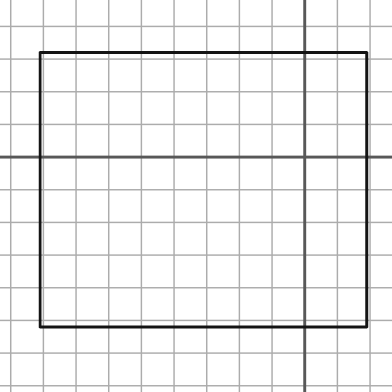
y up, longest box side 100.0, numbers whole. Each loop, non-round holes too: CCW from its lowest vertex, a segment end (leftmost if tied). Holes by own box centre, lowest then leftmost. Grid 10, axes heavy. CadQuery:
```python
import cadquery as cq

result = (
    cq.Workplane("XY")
    .moveTo(-81.0, -52.0)
    .lineTo(19.0, -52.0)
    .lineTo(19.0, 32.0)
    .lineTo(-81.0, 32.0)
    .close()
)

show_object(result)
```